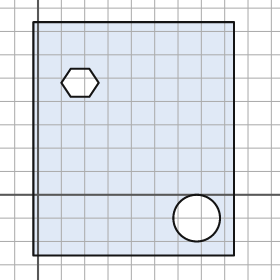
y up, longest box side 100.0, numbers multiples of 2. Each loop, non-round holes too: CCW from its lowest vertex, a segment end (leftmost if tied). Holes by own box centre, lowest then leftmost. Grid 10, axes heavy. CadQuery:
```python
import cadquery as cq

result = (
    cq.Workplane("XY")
    .moveTo(-2.0, -26.0)
    .lineTo(84.0, -26.0)
    .lineTo(84.0, 74.0)
    .lineTo(-2.0, 74.0)
    .close()
    .moveTo(68.0, -10.0)
    .circle(10.0)
    .moveTo(14.0, 42.0)
    .lineTo(22.0, 42.0)
    .lineTo(26.0, 48.0)
    .lineTo(22.0, 54.0)
    .lineTo(14.0, 54.0)
    .lineTo(10.0, 48.0)
    .close()
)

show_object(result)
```